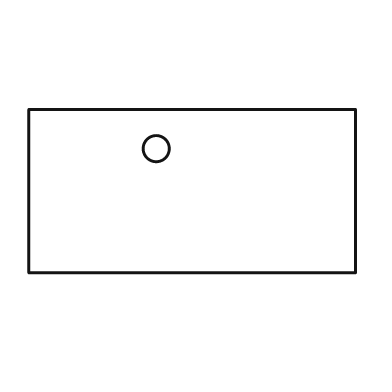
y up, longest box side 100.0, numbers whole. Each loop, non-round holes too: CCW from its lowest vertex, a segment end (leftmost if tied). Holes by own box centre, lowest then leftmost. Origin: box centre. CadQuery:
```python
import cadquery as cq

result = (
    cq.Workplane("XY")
    .moveTo(-50.0, -25.0)
    .lineTo(50.0, -25.0)
    .lineTo(50.0, 25.0)
    .lineTo(-50.0, 25.0)
    .close()
    .moveTo(-11.0, 13.0)
    .circle(4.0)
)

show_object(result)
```